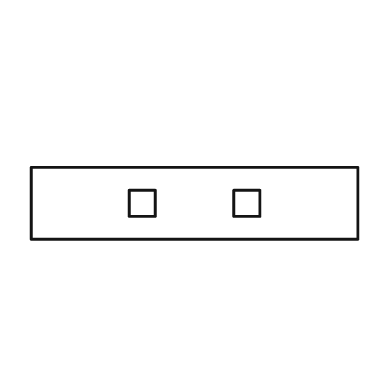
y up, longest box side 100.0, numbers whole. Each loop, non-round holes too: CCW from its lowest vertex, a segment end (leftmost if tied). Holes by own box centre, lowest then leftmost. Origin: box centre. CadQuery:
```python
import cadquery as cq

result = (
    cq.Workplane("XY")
    .moveTo(-50.0, -11.0)
    .lineTo(50.0, -11.0)
    .lineTo(50.0, 11.0)
    .lineTo(-50.0, 11.0)
    .close()
    .moveTo(-20.0, -4.0)
    .lineTo(-12.0, -4.0)
    .lineTo(-12.0, 4.0)
    .lineTo(-20.0, 4.0)
    .close()
    .moveTo(12.0, -4.0)
    .lineTo(20.0, -4.0)
    .lineTo(20.0, 4.0)
    .lineTo(12.0, 4.0)
    .close()
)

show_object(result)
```